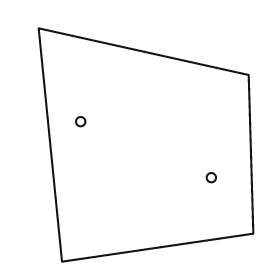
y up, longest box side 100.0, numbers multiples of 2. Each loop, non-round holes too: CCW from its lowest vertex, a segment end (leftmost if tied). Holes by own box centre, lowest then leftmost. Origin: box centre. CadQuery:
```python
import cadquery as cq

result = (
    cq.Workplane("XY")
    .moveTo(-36.0, -50.0)
    .lineTo(46.0, -38.0)
    .lineTo(44.0, 30.0)
    .lineTo(-46.0, 50.0)
    .close()
    .moveTo(28.0, -14.0)
    .circle(2.0)
    .moveTo(-28.0, 10.0)
    .circle(2.0)
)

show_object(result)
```